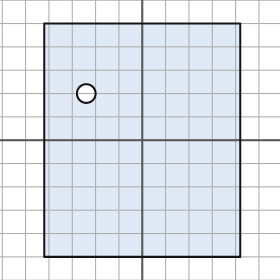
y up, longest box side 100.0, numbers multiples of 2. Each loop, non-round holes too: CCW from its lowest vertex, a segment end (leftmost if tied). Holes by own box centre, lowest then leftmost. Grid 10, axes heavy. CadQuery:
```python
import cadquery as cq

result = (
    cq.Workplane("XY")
    .moveTo(-42.0, -50.0)
    .lineTo(42.0, -50.0)
    .lineTo(42.0, 50.0)
    .lineTo(-42.0, 50.0)
    .close()
    .moveTo(-24.0, 20.0)
    .circle(4.0)
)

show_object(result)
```